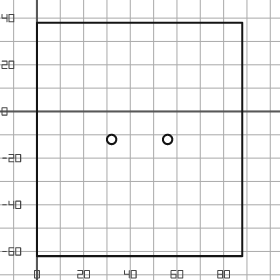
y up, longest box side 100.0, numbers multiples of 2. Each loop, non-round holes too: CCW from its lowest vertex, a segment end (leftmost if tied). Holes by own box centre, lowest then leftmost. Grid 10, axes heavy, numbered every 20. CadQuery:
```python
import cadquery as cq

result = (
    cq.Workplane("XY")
    .moveTo(0.0, -62.0)
    .lineTo(88.0, -62.0)
    .lineTo(88.0, 38.0)
    .lineTo(0.0, 38.0)
    .close()
    .moveTo(32.0, -12.0)
    .circle(2.0)
    .moveTo(56.0, -12.0)
    .circle(2.0)
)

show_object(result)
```